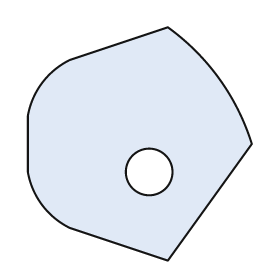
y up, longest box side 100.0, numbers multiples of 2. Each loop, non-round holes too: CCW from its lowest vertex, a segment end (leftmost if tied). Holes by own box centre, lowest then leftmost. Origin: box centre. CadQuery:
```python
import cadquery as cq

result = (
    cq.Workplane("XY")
    .moveTo(12.0, -50.0)
    .lineTo(48.0, 0.0)
    .threePointArc((34.0, 28.0), (12.0, 50.0))
    .lineTo(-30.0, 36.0)
    .threePointArc((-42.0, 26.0), (-48.0, 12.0))
    .lineTo(-48.0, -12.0)
    .threePointArc((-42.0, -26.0), (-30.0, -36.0))
    .close()
    .moveTo(4.0, -12.0)
    .circle(10.0)
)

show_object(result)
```